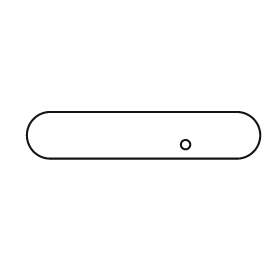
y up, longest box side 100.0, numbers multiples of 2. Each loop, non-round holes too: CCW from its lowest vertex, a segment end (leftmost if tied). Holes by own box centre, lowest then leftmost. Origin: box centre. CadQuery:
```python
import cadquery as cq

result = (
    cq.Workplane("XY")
    .moveTo(-40.0, -10.0)
    .lineTo(40.0, -10.0)
    .threePointArc((50.0, 0.0), (40.0, 10.0))
    .lineTo(-40.0, 10.0)
    .threePointArc((-50.0, 0.0), (-40.0, -10.0))
    .close()
    .moveTo(18.0, -4.0)
    .circle(2.0)
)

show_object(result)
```